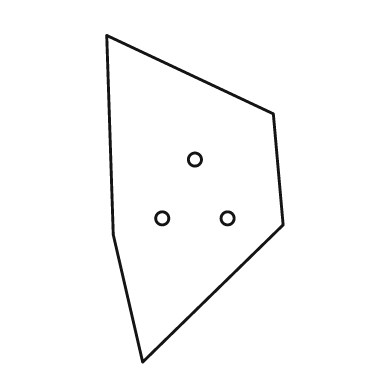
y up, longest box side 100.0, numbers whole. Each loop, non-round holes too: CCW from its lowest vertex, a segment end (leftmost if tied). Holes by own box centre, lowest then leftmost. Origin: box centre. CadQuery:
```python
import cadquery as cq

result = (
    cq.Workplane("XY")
    .moveTo(-16.0, -50.0)
    .lineTo(27.0, -8.0)
    .lineTo(24.0, 26.0)
    .lineTo(-27.0, 50.0)
    .lineTo(-25.0, -11.0)
    .close()
    .moveTo(-10.0, -6.0)
    .circle(2.0)
    .moveTo(10.0, -6.0)
    .circle(2.0)
    .moveTo(0.0, 12.0)
    .circle(2.0)
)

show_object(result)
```